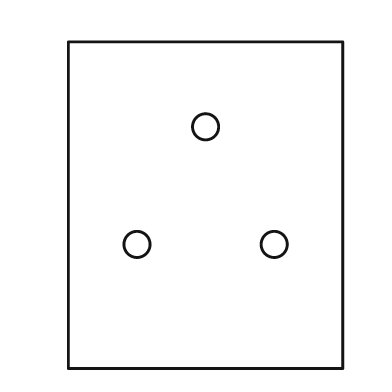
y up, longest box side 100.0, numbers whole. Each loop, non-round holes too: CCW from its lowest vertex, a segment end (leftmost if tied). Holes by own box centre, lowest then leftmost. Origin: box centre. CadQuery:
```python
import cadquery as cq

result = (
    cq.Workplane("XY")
    .moveTo(-42.0, -50.0)
    .lineTo(42.0, -50.0)
    .lineTo(42.0, 50.0)
    .lineTo(-42.0, 50.0)
    .close()
    .moveTo(-21.0, -12.0)
    .circle(4.0)
    .moveTo(21.0, -12.0)
    .circle(4.0)
    .moveTo(0.0, 24.0)
    .circle(4.0)
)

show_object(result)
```